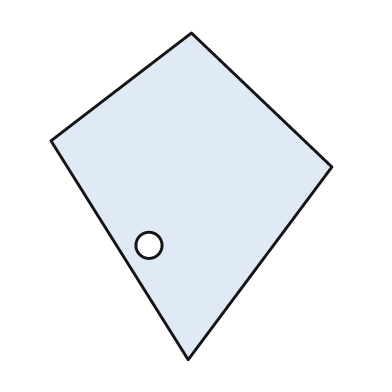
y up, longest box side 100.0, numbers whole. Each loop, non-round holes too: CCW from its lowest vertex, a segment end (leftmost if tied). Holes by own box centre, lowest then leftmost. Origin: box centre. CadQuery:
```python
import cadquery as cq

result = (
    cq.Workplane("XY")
    .moveTo(-1.0, -50.0)
    .lineTo(43.0, 9.0)
    .lineTo(0.0, 50.0)
    .lineTo(-43.0, 17.0)
    .close()
    .moveTo(-13.0, -15.0)
    .circle(4.0)
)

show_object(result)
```